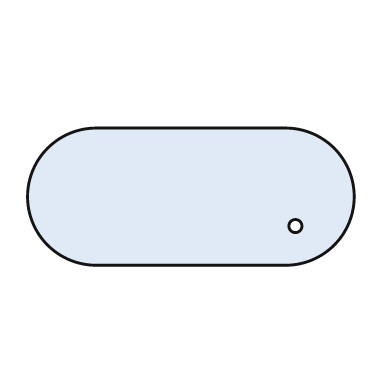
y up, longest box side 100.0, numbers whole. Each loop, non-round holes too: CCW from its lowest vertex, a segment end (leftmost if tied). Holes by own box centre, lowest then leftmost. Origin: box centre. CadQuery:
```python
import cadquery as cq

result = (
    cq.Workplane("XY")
    .moveTo(-29.0, -21.0)
    .lineTo(29.0, -21.0)
    .threePointArc((50.0, 0.0), (29.0, 21.0))
    .lineTo(-29.0, 21.0)
    .threePointArc((-50.0, 0.0), (-29.0, -21.0))
    .close()
    .moveTo(32.0, -9.0)
    .circle(2.0)
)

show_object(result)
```